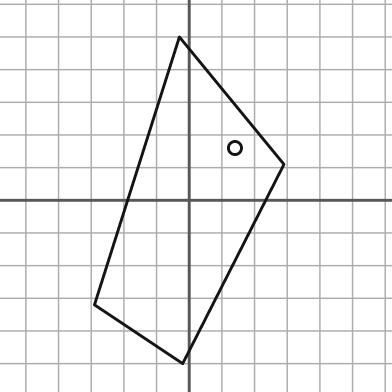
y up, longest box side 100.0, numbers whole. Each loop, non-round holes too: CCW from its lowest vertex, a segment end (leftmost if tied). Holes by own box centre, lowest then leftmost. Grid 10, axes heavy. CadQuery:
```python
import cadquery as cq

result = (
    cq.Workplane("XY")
    .moveTo(-2.0, -50.0)
    .lineTo(29.0, 11.0)
    .lineTo(-3.0, 50.0)
    .lineTo(-29.0, -32.0)
    .close()
    .moveTo(14.0, 16.0)
    .circle(2.0)
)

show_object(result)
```